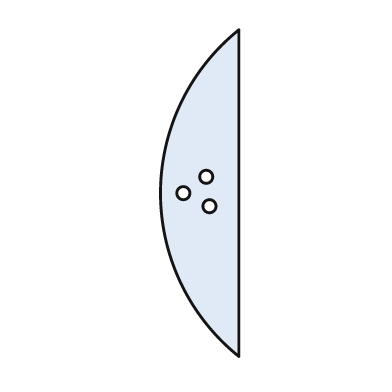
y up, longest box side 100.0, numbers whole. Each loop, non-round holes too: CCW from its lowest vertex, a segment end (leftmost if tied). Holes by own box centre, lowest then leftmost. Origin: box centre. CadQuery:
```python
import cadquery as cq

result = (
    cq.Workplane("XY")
    .moveTo(12.0, -50.0)
    .lineTo(12.0, 50.0)
    .threePointArc((-12.0, 0.0), (12.0, -50.0))
    .close()
    .moveTo(3.0, -4.0)
    .circle(2.0)
    .moveTo(-5.0, 0.0)
    .circle(2.0)
    .moveTo(2.0, 5.0)
    .circle(2.0)
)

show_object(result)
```